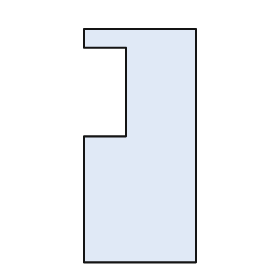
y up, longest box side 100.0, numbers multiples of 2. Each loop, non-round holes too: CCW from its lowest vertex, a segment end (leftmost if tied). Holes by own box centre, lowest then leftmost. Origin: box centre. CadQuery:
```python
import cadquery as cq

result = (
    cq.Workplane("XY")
    .moveTo(-24.0, -50.0)
    .lineTo(24.0, -50.0)
    .lineTo(24.0, 50.0)
    .lineTo(-24.0, 50.0)
    .lineTo(-24.0, 42.0)
    .lineTo(-6.0, 42.0)
    .lineTo(-6.0, 4.0)
    .lineTo(-24.0, 4.0)
    .close()
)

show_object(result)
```